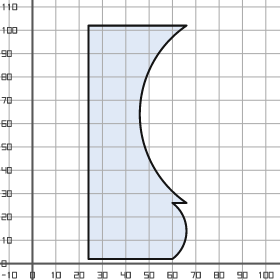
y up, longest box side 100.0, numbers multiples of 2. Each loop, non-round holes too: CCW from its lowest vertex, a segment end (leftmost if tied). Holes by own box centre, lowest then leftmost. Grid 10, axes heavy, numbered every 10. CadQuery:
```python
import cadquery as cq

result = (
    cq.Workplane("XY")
    .moveTo(24.0, 2.0)
    .lineTo(60.0, 2.0)
    .threePointArc((66.0, 14.0), (60.0, 26.0))
    .lineTo(66.0, 26.0)
    .threePointArc((46.0, 64.0), (66.0, 102.0))
    .lineTo(24.0, 102.0)
    .close()
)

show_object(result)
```